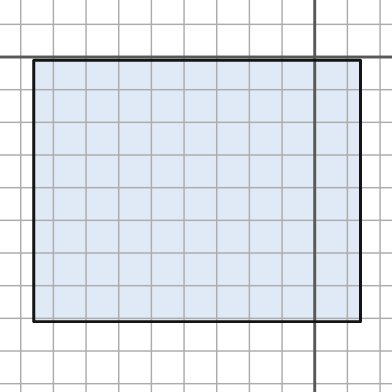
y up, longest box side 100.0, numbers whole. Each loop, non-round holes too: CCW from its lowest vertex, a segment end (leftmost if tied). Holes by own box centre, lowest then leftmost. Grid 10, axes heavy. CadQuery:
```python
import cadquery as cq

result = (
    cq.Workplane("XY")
    .moveTo(-86.0, -81.0)
    .lineTo(14.0, -81.0)
    .lineTo(14.0, -1.0)
    .lineTo(-86.0, -1.0)
    .close()
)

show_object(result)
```